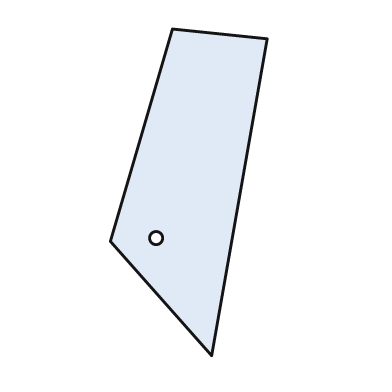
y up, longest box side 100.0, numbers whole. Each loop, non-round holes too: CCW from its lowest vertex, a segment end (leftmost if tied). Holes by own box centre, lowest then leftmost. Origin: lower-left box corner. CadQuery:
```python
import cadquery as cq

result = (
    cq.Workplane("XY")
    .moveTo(31.0, 0.0)
    .lineTo(48.0, 97.0)
    .lineTo(19.0, 100.0)
    .lineTo(0.0, 35.0)
    .close()
    .moveTo(14.0, 36.0)
    .circle(2.0)
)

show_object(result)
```